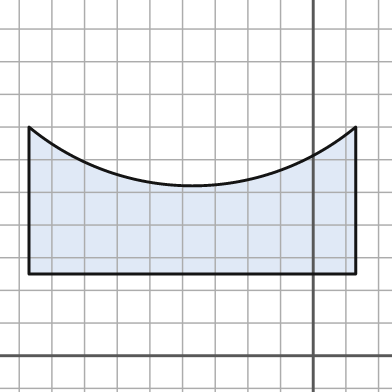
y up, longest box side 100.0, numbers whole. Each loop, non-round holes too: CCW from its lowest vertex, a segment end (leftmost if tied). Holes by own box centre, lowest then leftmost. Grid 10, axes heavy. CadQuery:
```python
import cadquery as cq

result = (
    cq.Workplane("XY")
    .moveTo(-87.0, 25.0)
    .lineTo(13.0, 25.0)
    .lineTo(13.0, 70.0)
    .threePointArc((-37.0, 52.0), (-87.0, 70.0))
    .close()
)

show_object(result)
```